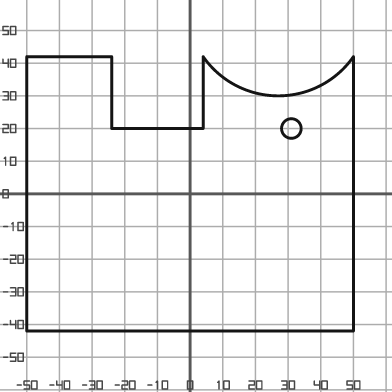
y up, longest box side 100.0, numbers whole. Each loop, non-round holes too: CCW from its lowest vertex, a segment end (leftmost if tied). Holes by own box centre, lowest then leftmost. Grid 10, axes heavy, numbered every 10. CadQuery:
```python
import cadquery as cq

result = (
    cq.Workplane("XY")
    .moveTo(-50.0, -42.0)
    .lineTo(50.0, -42.0)
    .lineTo(50.0, 42.0)
    .threePointArc((27.0, 30.0), (4.0, 42.0))
    .lineTo(4.0, 20.0)
    .lineTo(-24.0, 20.0)
    .lineTo(-24.0, 42.0)
    .lineTo(-50.0, 42.0)
    .close()
    .moveTo(31.0, 20.0)
    .circle(3.0)
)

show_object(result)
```